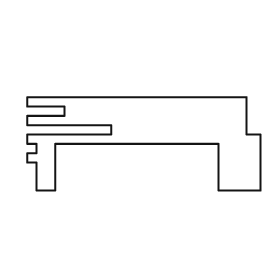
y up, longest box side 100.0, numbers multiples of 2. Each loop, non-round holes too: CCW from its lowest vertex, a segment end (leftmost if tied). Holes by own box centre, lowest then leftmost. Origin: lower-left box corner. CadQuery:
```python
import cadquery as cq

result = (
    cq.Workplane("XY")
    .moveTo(4.0, 0.0)
    .lineTo(12.0, 0.0)
    .lineTo(12.0, 20.0)
    .lineTo(82.0, 20.0)
    .lineTo(82.0, 0.0)
    .lineTo(100.0, 0.0)
    .lineTo(100.0, 24.0)
    .lineTo(94.0, 24.0)
    .lineTo(94.0, 40.0)
    .lineTo(0.0, 40.0)
    .lineTo(0.0, 36.0)
    .lineTo(16.0, 36.0)
    .lineTo(16.0, 32.0)
    .lineTo(0.0, 32.0)
    .lineTo(0.0, 28.0)
    .lineTo(36.0, 28.0)
    .lineTo(36.0, 24.0)
    .lineTo(0.0, 24.0)
    .lineTo(0.0, 20.0)
    .lineTo(4.0, 20.0)
    .lineTo(4.0, 16.0)
    .lineTo(0.0, 16.0)
    .lineTo(0.0, 12.0)
    .lineTo(4.0, 12.0)
    .close()
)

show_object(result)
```